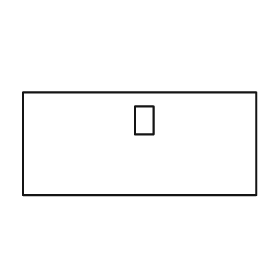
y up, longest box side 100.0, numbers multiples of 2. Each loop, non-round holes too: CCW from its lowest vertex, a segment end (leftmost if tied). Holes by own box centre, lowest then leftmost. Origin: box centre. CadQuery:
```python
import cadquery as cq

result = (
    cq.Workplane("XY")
    .moveTo(-50.0, -22.0)
    .lineTo(50.0, -22.0)
    .lineTo(50.0, 22.0)
    .lineTo(-50.0, 22.0)
    .close()
    .moveTo(-2.0, 4.0)
    .lineTo(6.0, 4.0)
    .lineTo(6.0, 16.0)
    .lineTo(-2.0, 16.0)
    .close()
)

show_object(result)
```